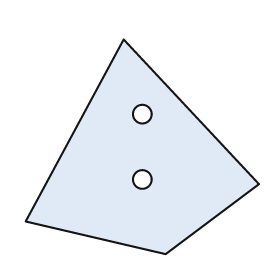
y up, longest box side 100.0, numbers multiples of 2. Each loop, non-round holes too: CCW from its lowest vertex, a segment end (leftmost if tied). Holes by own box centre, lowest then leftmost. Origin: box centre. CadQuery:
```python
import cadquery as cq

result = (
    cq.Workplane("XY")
    .moveTo(10.0, -46.0)
    .lineTo(50.0, -16.0)
    .lineTo(-8.0, 46.0)
    .lineTo(-50.0, -32.0)
    .close()
    .moveTo(0.0, -14.0)
    .circle(4.0)
    .moveTo(0.0, 14.0)
    .circle(4.0)
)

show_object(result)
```